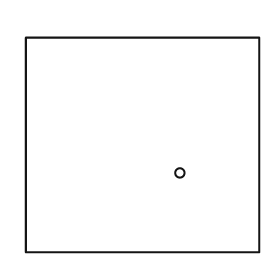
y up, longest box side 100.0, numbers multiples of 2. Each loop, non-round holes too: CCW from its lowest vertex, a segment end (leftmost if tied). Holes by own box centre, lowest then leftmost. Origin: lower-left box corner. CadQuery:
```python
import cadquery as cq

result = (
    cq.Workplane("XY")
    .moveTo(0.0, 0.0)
    .lineTo(100.0, 0.0)
    .lineTo(100.0, 92.0)
    .lineTo(0.0, 92.0)
    .close()
    .moveTo(66.0, 34.0)
    .circle(2.0)
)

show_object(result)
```